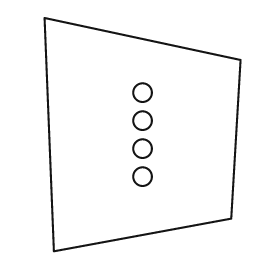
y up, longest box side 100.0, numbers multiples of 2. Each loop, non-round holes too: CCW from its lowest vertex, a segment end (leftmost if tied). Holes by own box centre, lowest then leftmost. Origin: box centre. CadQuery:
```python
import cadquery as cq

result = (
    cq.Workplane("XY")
    .moveTo(-38.0, -50.0)
    .lineTo(38.0, -36.0)
    .lineTo(42.0, 32.0)
    .lineTo(-42.0, 50.0)
    .close()
    .moveTo(0.0, -18.0)
    .circle(4.0)
    .moveTo(0.0, -6.0)
    .circle(4.0)
    .moveTo(0.0, 6.0)
    .circle(4.0)
    .moveTo(0.0, 18.0)
    .circle(4.0)
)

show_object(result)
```